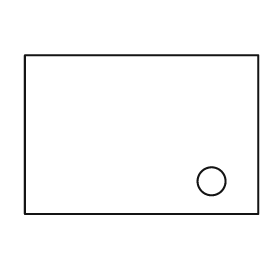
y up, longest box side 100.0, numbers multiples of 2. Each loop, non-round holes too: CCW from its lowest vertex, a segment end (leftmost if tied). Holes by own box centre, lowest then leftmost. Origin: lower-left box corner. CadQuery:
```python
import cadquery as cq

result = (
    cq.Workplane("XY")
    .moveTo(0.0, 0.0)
    .lineTo(100.0, 0.0)
    .lineTo(100.0, 68.0)
    .lineTo(0.0, 68.0)
    .close()
    .moveTo(80.0, 14.0)
    .circle(6.0)
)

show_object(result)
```